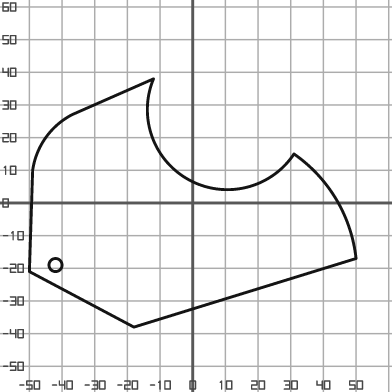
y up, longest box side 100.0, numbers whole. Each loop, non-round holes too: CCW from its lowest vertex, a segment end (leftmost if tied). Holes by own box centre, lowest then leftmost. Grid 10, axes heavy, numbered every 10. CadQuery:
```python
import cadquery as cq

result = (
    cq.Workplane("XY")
    .moveTo(-18.0, -38.0)
    .lineTo(50.0, -17.0)
    .threePointArc((44.0, 1.0), (31.0, 15.0))
    .threePointArc((-1.0, 7.0), (-12.0, 38.0))
    .lineTo(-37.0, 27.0)
    .threePointArc((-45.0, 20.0), (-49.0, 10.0))
    .lineTo(-50.0, -21.0)
    .close()
    .moveTo(-42.0, -19.0)
    .circle(2.0)
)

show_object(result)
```